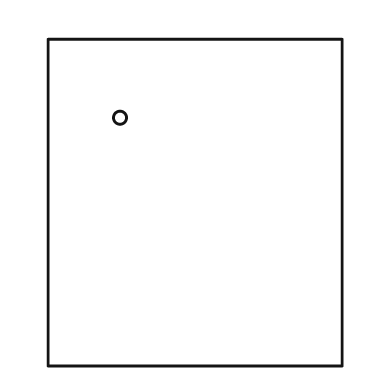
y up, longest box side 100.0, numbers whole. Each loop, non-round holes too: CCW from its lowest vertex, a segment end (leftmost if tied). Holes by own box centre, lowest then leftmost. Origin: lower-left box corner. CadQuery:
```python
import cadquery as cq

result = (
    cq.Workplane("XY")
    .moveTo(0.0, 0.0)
    .lineTo(90.0, 0.0)
    .lineTo(90.0, 100.0)
    .lineTo(0.0, 100.0)
    .close()
    .moveTo(22.0, 76.0)
    .circle(2.0)
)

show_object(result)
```